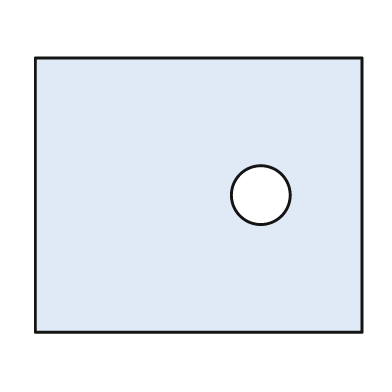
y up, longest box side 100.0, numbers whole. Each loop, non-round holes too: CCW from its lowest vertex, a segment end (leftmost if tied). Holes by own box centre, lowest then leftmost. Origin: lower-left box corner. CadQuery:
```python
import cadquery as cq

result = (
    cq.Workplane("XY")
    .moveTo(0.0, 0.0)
    .lineTo(100.0, 0.0)
    .lineTo(100.0, 84.0)
    .lineTo(0.0, 84.0)
    .close()
    .moveTo(69.0, 42.0)
    .circle(9.0)
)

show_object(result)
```